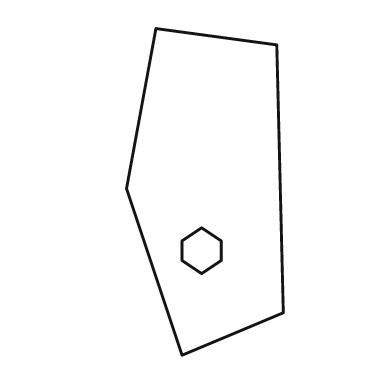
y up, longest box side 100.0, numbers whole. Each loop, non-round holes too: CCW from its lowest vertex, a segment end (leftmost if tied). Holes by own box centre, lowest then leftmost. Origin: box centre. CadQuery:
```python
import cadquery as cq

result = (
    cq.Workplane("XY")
    .moveTo(-7.0, -50.0)
    .lineTo(24.0, -37.0)
    .lineTo(22.0, 45.0)
    .lineTo(-15.0, 50.0)
    .lineTo(-24.0, 1.0)
    .close()
    .moveTo(-1.0, -25.0)
    .lineTo(5.0, -21.0)
    .lineTo(5.0, -15.0)
    .lineTo(-1.0, -11.0)
    .lineTo(-7.0, -15.0)
    .lineTo(-7.0, -21.0)
    .close()
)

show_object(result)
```